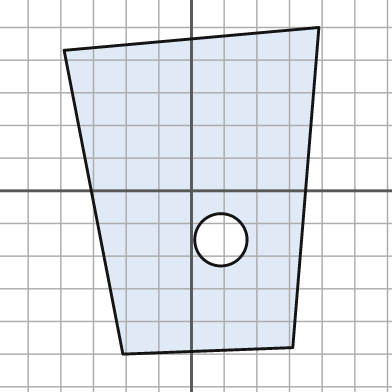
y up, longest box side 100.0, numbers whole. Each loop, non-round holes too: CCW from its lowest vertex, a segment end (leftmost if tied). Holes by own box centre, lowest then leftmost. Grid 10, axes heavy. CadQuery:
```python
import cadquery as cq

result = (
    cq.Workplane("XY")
    .moveTo(-21.0, -50.0)
    .lineTo(31.0, -48.0)
    .lineTo(39.0, 50.0)
    .lineTo(-39.0, 43.0)
    .close()
    .moveTo(9.0, -15.0)
    .circle(8.0)
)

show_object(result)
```